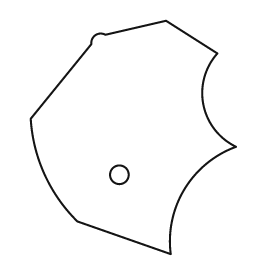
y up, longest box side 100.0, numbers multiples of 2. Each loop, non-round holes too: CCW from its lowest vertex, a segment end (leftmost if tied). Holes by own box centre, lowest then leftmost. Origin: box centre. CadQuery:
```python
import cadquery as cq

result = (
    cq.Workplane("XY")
    .moveTo(16.0, -50.0)
    .threePointArc((22.0, -22.0), (44.0, -4.0))
    .threePointArc((30.0, 14.0), (36.0, 36.0))
    .lineTo(14.0, 50.0)
    .lineTo(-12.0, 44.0)
    .threePointArc((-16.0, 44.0), (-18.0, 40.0))
    .lineTo(-44.0, 8.0)
    .threePointArc((-38.0, -16.0), (-24.0, -36.0))
    .close()
    .moveTo(-6.0, -16.0)
    .circle(4.0)
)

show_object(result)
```